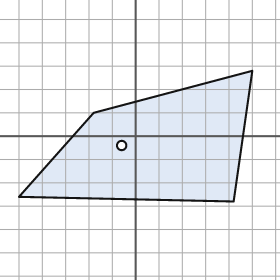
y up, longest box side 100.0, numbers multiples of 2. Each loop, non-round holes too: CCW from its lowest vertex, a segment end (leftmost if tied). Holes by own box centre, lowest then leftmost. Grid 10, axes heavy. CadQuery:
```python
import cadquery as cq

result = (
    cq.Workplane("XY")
    .moveTo(42.0, -28.0)
    .lineTo(50.0, 28.0)
    .lineTo(-18.0, 10.0)
    .lineTo(-50.0, -26.0)
    .close()
    .moveTo(-6.0, -4.0)
    .circle(2.0)
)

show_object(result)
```